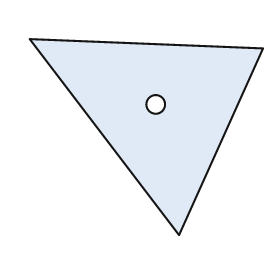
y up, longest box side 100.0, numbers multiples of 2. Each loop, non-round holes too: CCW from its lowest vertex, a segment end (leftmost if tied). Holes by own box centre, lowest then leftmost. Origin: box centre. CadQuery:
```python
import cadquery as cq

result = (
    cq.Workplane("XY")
    .moveTo(14.0, -42.0)
    .lineTo(50.0, 38.0)
    .lineTo(-50.0, 42.0)
    .close()
    .moveTo(4.0, 14.0)
    .circle(4.0)
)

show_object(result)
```